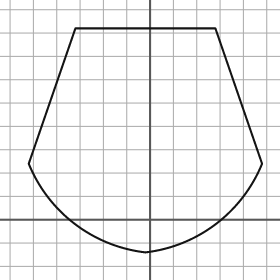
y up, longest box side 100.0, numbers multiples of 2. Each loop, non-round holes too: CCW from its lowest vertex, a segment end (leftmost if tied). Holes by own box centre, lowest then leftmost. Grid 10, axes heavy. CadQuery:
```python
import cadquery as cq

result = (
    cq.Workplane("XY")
    .moveTo(-2.0, -14.0)
    .threePointArc((28.0, -2.0), (48.0, 24.0))
    .lineTo(28.0, 82.0)
    .lineTo(-32.0, 82.0)
    .lineTo(-52.0, 24.0)
    .threePointArc((-32.0, -2.0), (-2.0, -14.0))
    .close()
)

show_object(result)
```